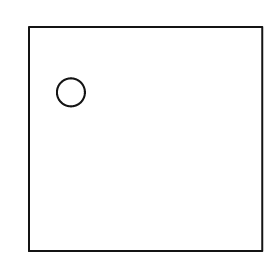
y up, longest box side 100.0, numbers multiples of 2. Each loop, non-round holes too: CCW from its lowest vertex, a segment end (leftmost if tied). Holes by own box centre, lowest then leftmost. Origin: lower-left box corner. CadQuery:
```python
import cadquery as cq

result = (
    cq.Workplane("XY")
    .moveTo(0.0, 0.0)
    .lineTo(100.0, 0.0)
    .lineTo(100.0, 96.0)
    .lineTo(0.0, 96.0)
    .close()
    .moveTo(18.0, 68.0)
    .circle(6.0)
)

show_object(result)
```